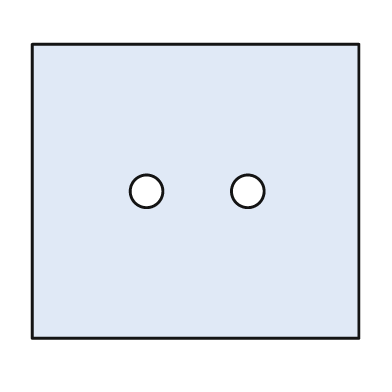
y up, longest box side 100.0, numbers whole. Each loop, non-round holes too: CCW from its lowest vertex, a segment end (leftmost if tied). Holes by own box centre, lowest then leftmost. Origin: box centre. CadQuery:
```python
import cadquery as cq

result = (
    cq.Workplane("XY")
    .moveTo(-50.0, -45.0)
    .lineTo(50.0, -45.0)
    .lineTo(50.0, 45.0)
    .lineTo(-50.0, 45.0)
    .close()
    .moveTo(-15.0, 0.0)
    .circle(5.0)
    .moveTo(16.0, 0.0)
    .circle(5.0)
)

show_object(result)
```